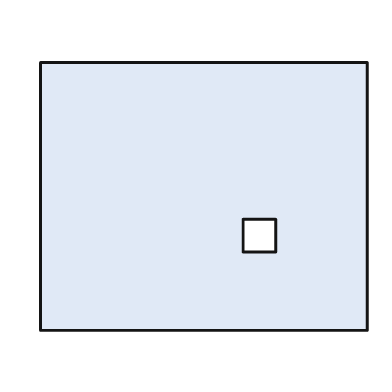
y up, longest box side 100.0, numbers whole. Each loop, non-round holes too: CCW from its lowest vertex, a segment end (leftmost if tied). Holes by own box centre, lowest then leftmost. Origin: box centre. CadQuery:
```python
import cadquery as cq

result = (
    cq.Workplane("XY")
    .moveTo(-50.0, -41.0)
    .lineTo(50.0, -41.0)
    .lineTo(50.0, 41.0)
    .lineTo(-50.0, 41.0)
    .close()
    .moveTo(12.0, -17.0)
    .lineTo(22.0, -17.0)
    .lineTo(22.0, -7.0)
    .lineTo(12.0, -7.0)
    .close()
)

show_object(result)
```